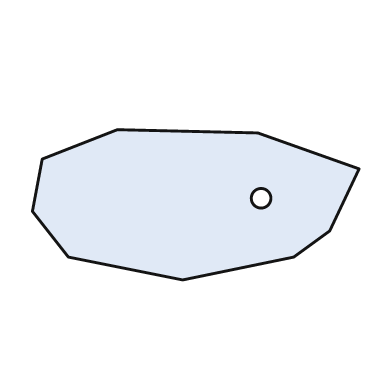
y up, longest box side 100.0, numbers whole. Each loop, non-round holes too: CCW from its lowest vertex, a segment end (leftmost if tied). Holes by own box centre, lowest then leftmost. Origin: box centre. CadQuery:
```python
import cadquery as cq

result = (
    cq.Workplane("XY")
    .moveTo(-4.0, -23.0)
    .lineTo(30.0, -16.0)
    .lineTo(41.0, -8.0)
    .lineTo(50.0, 11.0)
    .lineTo(19.0, 22.0)
    .lineTo(-24.0, 23.0)
    .lineTo(-47.0, 14.0)
    .lineTo(-50.0, -2.0)
    .lineTo(-39.0, -16.0)
    .close()
    .moveTo(20.0, 2.0)
    .circle(3.0)
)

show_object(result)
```